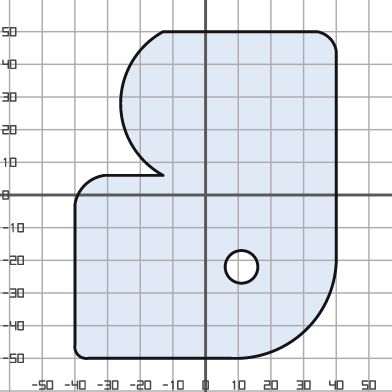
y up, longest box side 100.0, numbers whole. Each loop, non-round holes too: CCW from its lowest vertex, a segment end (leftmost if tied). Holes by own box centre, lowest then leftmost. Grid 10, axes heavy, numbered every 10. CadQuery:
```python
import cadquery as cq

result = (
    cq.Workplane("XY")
    .moveTo(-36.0, -50.0)
    .lineTo(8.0, -50.0)
    .threePointArc((31.0, -41.0), (40.0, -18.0))
    .lineTo(40.0, 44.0)
    .threePointArc((38.0, 48.0), (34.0, 50.0))
    .lineTo(-13.0, 50.0)
    .threePointArc((-26.0, 28.0), (-13.0, 6.0))
    .lineTo(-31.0, 6.0)
    .threePointArc((-37.0, 3.0), (-40.0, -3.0))
    .lineTo(-40.0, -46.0)
    .threePointArc((-39.0, -49.0), (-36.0, -50.0))
    .close()
    .moveTo(11.0, -22.0)
    .circle(5.0)
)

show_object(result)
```